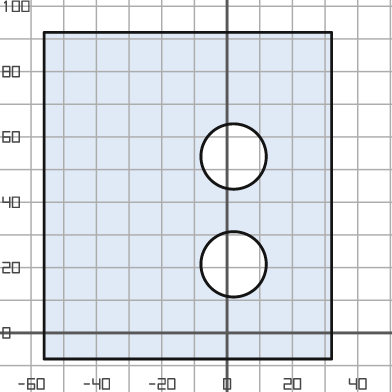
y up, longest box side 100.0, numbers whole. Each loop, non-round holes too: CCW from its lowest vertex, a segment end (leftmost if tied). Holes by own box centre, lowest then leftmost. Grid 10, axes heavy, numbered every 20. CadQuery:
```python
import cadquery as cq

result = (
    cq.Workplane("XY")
    .moveTo(-56.0, -8.0)
    .lineTo(32.0, -8.0)
    .lineTo(32.0, 92.0)
    .lineTo(-56.0, 92.0)
    .close()
    .moveTo(2.0, 21.0)
    .circle(10.0)
    .moveTo(2.0, 54.0)
    .circle(10.0)
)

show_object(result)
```